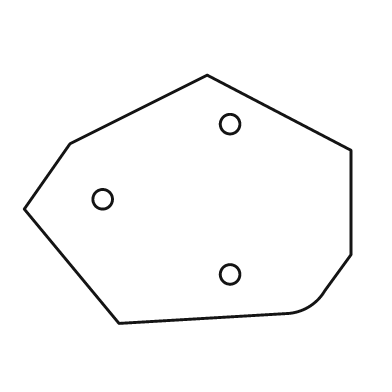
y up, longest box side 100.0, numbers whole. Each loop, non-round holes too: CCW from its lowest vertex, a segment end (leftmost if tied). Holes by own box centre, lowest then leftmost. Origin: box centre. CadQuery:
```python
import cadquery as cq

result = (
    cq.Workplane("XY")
    .moveTo(-21.0, -38.0)
    .lineTo(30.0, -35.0)
    .threePointArc((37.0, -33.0), (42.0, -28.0))
    .lineTo(50.0, -17.0)
    .lineTo(50.0, 15.0)
    .lineTo(6.0, 38.0)
    .lineTo(-36.0, 17.0)
    .lineTo(-50.0, -3.0)
    .close()
    .moveTo(13.0, -23.0)
    .circle(3.0)
    .moveTo(-26.0, 0.0)
    .circle(3.0)
    .moveTo(13.0, 23.0)
    .circle(3.0)
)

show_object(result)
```